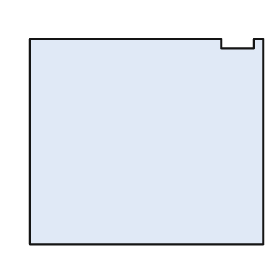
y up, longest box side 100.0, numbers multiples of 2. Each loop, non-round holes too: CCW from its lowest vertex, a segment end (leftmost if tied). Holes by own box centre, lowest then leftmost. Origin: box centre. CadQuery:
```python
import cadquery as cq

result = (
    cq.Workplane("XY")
    .moveTo(-50.0, -44.0)
    .lineTo(50.0, -44.0)
    .lineTo(50.0, 44.0)
    .lineTo(46.0, 44.0)
    .lineTo(46.0, 40.0)
    .lineTo(32.0, 40.0)
    .lineTo(32.0, 44.0)
    .lineTo(-50.0, 44.0)
    .close()
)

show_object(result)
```